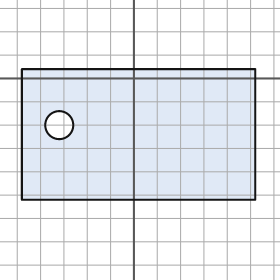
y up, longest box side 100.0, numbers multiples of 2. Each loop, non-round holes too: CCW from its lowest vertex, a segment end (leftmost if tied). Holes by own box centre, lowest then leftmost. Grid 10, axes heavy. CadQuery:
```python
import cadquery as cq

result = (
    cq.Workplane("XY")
    .moveTo(-48.0, -52.0)
    .lineTo(52.0, -52.0)
    .lineTo(52.0, 4.0)
    .lineTo(-48.0, 4.0)
    .close()
    .moveTo(-32.0, -20.0)
    .circle(6.0)
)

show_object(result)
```